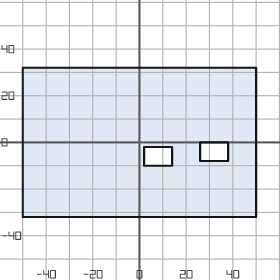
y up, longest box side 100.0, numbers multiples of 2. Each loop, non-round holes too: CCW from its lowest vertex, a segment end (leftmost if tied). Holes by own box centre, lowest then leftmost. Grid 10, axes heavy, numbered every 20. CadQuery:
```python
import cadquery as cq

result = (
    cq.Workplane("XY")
    .moveTo(-50.0, -32.0)
    .lineTo(50.0, -32.0)
    .lineTo(50.0, 32.0)
    .lineTo(-50.0, 32.0)
    .close()
    .moveTo(2.0, -10.0)
    .lineTo(14.0, -10.0)
    .lineTo(14.0, -2.0)
    .lineTo(2.0, -2.0)
    .close()
    .moveTo(26.0, -8.0)
    .lineTo(38.0, -8.0)
    .lineTo(38.0, 0.0)
    .lineTo(26.0, 0.0)
    .close()
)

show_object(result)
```